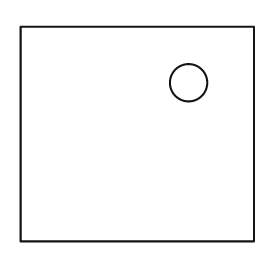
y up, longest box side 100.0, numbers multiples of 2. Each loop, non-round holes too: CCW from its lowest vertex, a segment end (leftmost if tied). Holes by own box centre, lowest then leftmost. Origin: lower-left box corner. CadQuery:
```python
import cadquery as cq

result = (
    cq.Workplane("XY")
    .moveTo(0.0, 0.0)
    .lineTo(100.0, 0.0)
    .lineTo(100.0, 92.0)
    .lineTo(0.0, 92.0)
    .close()
    .moveTo(72.0, 68.0)
    .circle(8.0)
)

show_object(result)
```